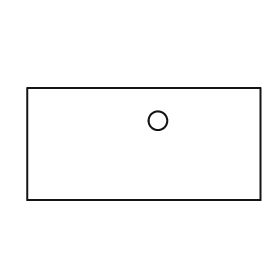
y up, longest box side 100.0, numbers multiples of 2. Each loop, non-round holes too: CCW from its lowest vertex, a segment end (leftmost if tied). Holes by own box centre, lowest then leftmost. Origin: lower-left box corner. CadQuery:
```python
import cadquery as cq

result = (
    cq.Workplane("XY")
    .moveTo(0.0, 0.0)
    .lineTo(100.0, 0.0)
    .lineTo(100.0, 48.0)
    .lineTo(0.0, 48.0)
    .close()
    .moveTo(56.0, 34.0)
    .circle(4.0)
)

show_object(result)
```